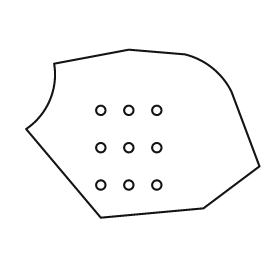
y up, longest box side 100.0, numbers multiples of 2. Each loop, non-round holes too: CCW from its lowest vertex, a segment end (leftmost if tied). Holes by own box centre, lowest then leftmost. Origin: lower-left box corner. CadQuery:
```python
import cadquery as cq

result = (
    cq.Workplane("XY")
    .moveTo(32.0, 0.0)
    .lineTo(76.0, 4.0)
    .lineTo(100.0, 22.0)
    .lineTo(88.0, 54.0)
    .threePointArc((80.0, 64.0), (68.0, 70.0))
    .lineTo(44.0, 72.0)
    .lineTo(12.0, 66.0)
    .threePointArc((10.0, 50.0), (0.0, 38.0))
    .close()
    .moveTo(32.0, 14.0)
    .circle(2.0)
    .moveTo(44.0, 14.0)
    .circle(2.0)
    .moveTo(56.0, 14.0)
    .circle(2.0)
    .moveTo(32.0, 30.0)
    .circle(2.0)
    .moveTo(44.0, 30.0)
    .circle(2.0)
    .moveTo(56.0, 30.0)
    .circle(2.0)
    .moveTo(32.0, 46.0)
    .circle(2.0)
    .moveTo(44.0, 46.0)
    .circle(2.0)
    .moveTo(56.0, 46.0)
    .circle(2.0)
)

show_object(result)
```